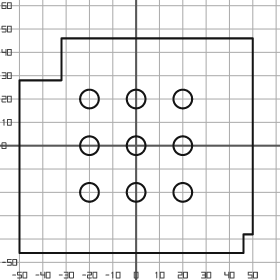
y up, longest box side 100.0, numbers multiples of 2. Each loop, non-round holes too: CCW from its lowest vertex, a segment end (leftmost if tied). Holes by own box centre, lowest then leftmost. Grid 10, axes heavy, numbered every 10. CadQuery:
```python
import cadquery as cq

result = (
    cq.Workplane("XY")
    .moveTo(-50.0, -46.0)
    .lineTo(46.0, -46.0)
    .lineTo(46.0, -38.0)
    .lineTo(50.0, -38.0)
    .lineTo(50.0, 46.0)
    .lineTo(-32.0, 46.0)
    .lineTo(-32.0, 28.0)
    .lineTo(-50.0, 28.0)
    .close()
    .moveTo(-20.0, -20.0)
    .circle(4.0)
    .moveTo(0.0, -20.0)
    .circle(4.0)
    .moveTo(20.0, -20.0)
    .circle(4.0)
    .moveTo(-20.0, 0.0)
    .circle(4.0)
    .moveTo(0.0, 0.0)
    .circle(4.0)
    .moveTo(20.0, 0.0)
    .circle(4.0)
    .moveTo(-20.0, 20.0)
    .circle(4.0)
    .moveTo(0.0, 20.0)
    .circle(4.0)
    .moveTo(20.0, 20.0)
    .circle(4.0)
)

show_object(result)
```